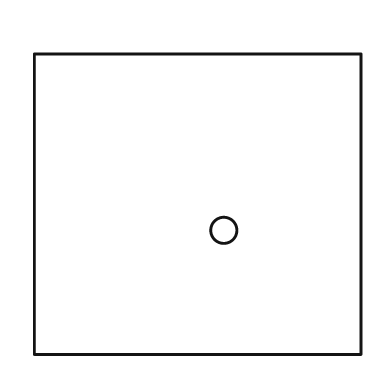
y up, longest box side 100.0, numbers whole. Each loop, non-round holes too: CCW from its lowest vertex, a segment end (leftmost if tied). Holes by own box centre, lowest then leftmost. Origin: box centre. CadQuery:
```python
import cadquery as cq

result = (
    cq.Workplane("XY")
    .moveTo(-50.0, -46.0)
    .lineTo(50.0, -46.0)
    .lineTo(50.0, 46.0)
    .lineTo(-50.0, 46.0)
    .close()
    .moveTo(8.0, -8.0)
    .circle(4.0)
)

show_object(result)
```